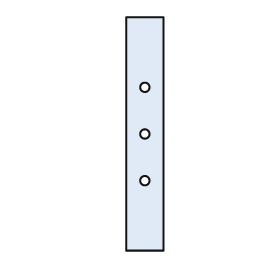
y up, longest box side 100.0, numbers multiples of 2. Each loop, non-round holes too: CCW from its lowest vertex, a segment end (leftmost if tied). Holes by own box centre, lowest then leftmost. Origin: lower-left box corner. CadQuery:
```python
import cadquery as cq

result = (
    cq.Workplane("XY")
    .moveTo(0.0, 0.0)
    .lineTo(16.0, 0.0)
    .lineTo(16.0, 100.0)
    .lineTo(0.0, 100.0)
    .close()
    .moveTo(8.0, 30.0)
    .circle(2.0)
    .moveTo(8.0, 50.0)
    .circle(2.0)
    .moveTo(8.0, 70.0)
    .circle(2.0)
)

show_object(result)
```